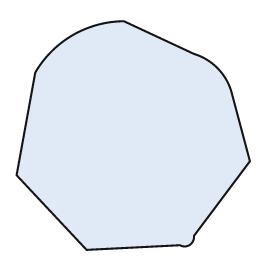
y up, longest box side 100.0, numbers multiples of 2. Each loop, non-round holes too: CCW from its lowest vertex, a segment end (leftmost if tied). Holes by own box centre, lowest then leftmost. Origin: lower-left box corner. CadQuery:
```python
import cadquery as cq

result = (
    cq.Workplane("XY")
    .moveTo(30.0, 0.0)
    .lineTo(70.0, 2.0)
    .threePointArc((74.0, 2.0), (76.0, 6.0))
    .lineTo(100.0, 38.0)
    .lineTo(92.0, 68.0)
    .threePointArc((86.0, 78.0), (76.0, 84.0))
    .lineTo(46.0, 98.0)
    .threePointArc((24.0, 92.0), (8.0, 76.0))
    .lineTo(0.0, 32.0)
    .close()
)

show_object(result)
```